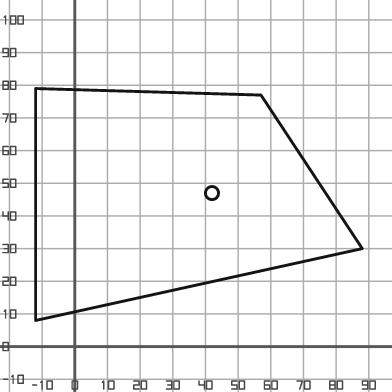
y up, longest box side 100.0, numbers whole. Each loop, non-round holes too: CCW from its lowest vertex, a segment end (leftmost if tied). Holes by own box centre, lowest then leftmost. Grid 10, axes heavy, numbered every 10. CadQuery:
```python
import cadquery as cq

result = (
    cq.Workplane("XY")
    .moveTo(-12.0, 8.0)
    .lineTo(88.0, 30.0)
    .lineTo(57.0, 77.0)
    .lineTo(-12.0, 79.0)
    .close()
    .moveTo(42.0, 47.0)
    .circle(2.0)
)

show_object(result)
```